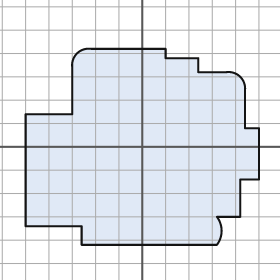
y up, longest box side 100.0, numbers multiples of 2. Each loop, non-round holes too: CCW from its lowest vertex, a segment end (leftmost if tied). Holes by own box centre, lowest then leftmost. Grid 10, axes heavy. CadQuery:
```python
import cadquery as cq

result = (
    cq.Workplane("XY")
    .moveTo(-26.0, -42.0)
    .lineTo(32.0, -42.0)
    .threePointArc((34.0, -36.0), (32.0, -30.0))
    .lineTo(42.0, -30.0)
    .lineTo(42.0, -14.0)
    .lineTo(50.0, -14.0)
    .lineTo(50.0, 8.0)
    .lineTo(44.0, 8.0)
    .lineTo(44.0, 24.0)
    .threePointArc((42.0, 30.0), (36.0, 32.0))
    .lineTo(24.0, 32.0)
    .lineTo(24.0, 38.0)
    .lineTo(10.0, 38.0)
    .lineTo(10.0, 42.0)
    .lineTo(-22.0, 42.0)
    .threePointArc((-28.0, 40.0), (-30.0, 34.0))
    .lineTo(-30.0, 14.0)
    .lineTo(-50.0, 14.0)
    .lineTo(-50.0, -34.0)
    .lineTo(-26.0, -34.0)
    .close()
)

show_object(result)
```